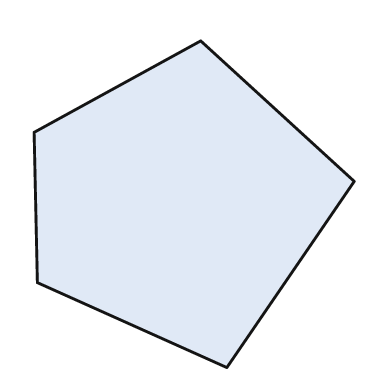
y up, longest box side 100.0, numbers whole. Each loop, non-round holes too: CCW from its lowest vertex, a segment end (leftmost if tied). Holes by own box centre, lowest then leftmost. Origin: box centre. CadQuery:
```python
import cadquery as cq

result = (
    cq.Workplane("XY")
    .moveTo(10.0, -50.0)
    .lineTo(49.0, 7.0)
    .lineTo(2.0, 50.0)
    .lineTo(-49.0, 22.0)
    .lineTo(-48.0, -24.0)
    .close()
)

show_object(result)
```